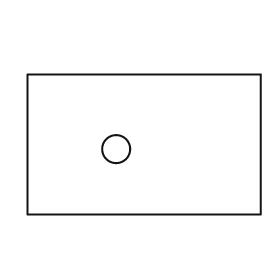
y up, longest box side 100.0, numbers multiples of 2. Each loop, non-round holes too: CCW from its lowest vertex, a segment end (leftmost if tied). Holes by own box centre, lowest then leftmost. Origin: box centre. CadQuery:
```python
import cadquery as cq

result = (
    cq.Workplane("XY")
    .moveTo(-50.0, -30.0)
    .lineTo(50.0, -30.0)
    .lineTo(50.0, 30.0)
    .lineTo(-50.0, 30.0)
    .close()
    .moveTo(-12.0, -2.0)
    .circle(6.0)
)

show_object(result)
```